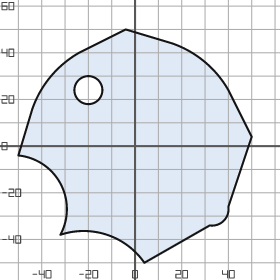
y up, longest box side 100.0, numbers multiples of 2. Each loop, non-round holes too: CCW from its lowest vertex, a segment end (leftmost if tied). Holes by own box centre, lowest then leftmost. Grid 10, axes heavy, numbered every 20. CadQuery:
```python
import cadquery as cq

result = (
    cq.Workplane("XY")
    .moveTo(4.0, -50.0)
    .lineTo(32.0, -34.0)
    .threePointArc((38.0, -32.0), (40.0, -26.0))
    .lineTo(50.0, 4.0)
    .lineTo(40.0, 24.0)
    .threePointArc((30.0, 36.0), (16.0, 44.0))
    .lineTo(-4.0, 50.0)
    .lineTo(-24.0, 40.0)
    .threePointArc((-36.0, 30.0), (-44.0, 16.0))
    .lineTo(-50.0, -4.0)
    .threePointArc((-32.0, -16.0), (-32.0, -38.0))
    .threePointArc((-12.0, -38.0), (4.0, -50.0))
    .close()
    .moveTo(-20.0, 24.0)
    .circle(6.0)
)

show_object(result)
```